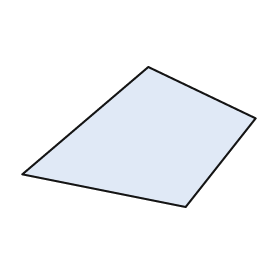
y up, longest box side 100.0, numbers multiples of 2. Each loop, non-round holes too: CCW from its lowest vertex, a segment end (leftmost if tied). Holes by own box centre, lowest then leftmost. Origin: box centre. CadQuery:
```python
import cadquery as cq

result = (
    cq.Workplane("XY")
    .moveTo(20.0, -30.0)
    .lineTo(50.0, 8.0)
    .lineTo(4.0, 30.0)
    .lineTo(-50.0, -16.0)
    .close()
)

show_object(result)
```